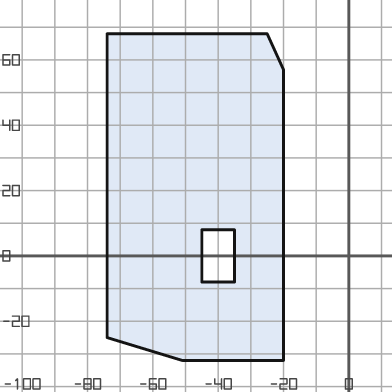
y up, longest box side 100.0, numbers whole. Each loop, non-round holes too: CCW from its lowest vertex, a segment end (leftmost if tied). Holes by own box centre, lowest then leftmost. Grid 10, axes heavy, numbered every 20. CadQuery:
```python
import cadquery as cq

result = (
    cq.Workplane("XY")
    .moveTo(-51.0, -32.0)
    .lineTo(-20.0, -32.0)
    .lineTo(-20.0, 57.0)
    .lineTo(-25.0, 68.0)
    .lineTo(-74.0, 68.0)
    .lineTo(-74.0, -25.0)
    .close()
    .moveTo(-45.0, -8.0)
    .lineTo(-35.0, -8.0)
    .lineTo(-35.0, 8.0)
    .lineTo(-45.0, 8.0)
    .close()
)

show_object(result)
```